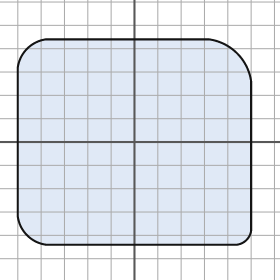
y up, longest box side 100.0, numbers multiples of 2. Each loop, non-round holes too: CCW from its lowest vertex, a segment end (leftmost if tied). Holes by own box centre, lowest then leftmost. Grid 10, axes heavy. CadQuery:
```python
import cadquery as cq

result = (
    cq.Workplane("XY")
    .moveTo(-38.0, -44.0)
    .lineTo(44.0, -44.0)
    .threePointArc((48.0, -42.0), (50.0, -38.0))
    .lineTo(50.0, 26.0)
    .threePointArc((44.0, 38.0), (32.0, 44.0))
    .lineTo(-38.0, 44.0)
    .threePointArc((-46.0, 40.0), (-50.0, 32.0))
    .lineTo(-50.0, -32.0)
    .threePointArc((-46.0, -40.0), (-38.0, -44.0))
    .close()
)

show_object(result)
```